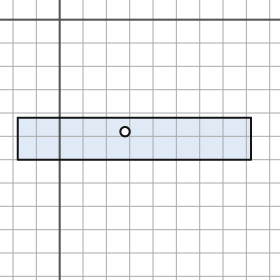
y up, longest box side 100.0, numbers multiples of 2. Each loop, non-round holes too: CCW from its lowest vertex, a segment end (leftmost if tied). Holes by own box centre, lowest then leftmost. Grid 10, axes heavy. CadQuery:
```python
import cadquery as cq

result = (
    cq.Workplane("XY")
    .moveTo(-18.0, -60.0)
    .lineTo(82.0, -60.0)
    .lineTo(82.0, -42.0)
    .lineTo(-18.0, -42.0)
    .close()
    .moveTo(28.0, -48.0)
    .circle(2.0)
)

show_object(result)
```